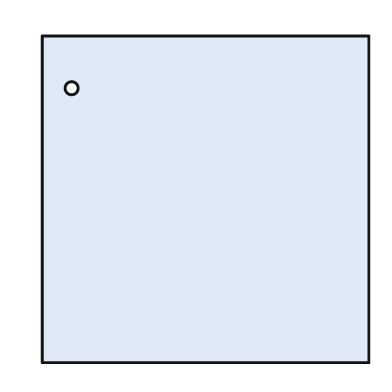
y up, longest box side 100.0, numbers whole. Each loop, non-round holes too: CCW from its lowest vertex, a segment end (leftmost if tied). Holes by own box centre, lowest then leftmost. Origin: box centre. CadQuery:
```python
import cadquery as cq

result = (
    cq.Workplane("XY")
    .moveTo(-50.0, -50.0)
    .lineTo(50.0, -50.0)
    .lineTo(50.0, 50.0)
    .lineTo(-50.0, 50.0)
    .close()
    .moveTo(-41.0, 34.0)
    .circle(2.0)
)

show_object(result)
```